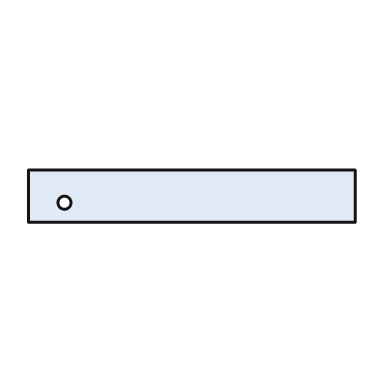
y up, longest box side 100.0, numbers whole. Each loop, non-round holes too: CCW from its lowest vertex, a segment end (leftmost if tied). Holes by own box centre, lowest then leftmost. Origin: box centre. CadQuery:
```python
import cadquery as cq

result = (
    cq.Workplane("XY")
    .moveTo(-50.0, -8.0)
    .lineTo(50.0, -8.0)
    .lineTo(50.0, 8.0)
    .lineTo(-50.0, 8.0)
    .close()
    .moveTo(-39.0, -2.0)
    .circle(2.0)
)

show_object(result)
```